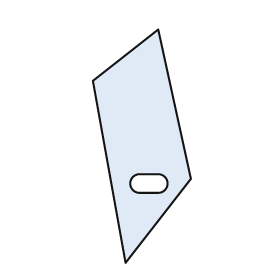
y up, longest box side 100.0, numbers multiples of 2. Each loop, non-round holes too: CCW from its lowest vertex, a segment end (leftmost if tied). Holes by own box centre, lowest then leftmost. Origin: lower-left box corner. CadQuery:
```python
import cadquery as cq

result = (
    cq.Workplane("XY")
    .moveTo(14.0, 0.0)
    .lineTo(42.0, 36.0)
    .lineTo(28.0, 100.0)
    .lineTo(0.0, 78.0)
    .close()
    .moveTo(20.0, 30.0)
    .lineTo(28.0, 30.0)
    .threePointArc((32.0, 34.0), (28.0, 38.0))
    .lineTo(20.0, 38.0)
    .threePointArc((16.0, 34.0), (20.0, 30.0))
    .close()
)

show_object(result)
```